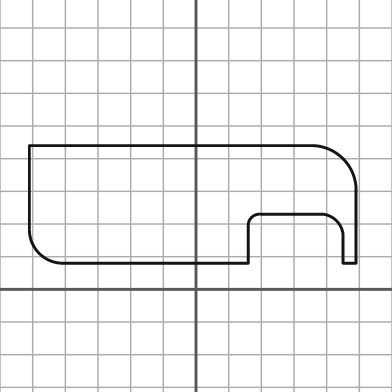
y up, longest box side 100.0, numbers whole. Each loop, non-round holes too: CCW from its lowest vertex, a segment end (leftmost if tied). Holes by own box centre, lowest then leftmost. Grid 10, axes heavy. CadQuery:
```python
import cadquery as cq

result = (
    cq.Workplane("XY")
    .moveTo(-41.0, 8.0)
    .lineTo(16.0, 8.0)
    .lineTo(16.0, 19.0)
    .threePointArc((17.0, 22.0), (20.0, 23.0))
    .lineTo(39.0, 23.0)
    .threePointArc((43.0, 21.0), (45.0, 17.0))
    .lineTo(45.0, 8.0)
    .lineTo(49.0, 8.0)
    .lineTo(49.0, 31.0)
    .threePointArc((45.0, 40.0), (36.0, 44.0))
    .lineTo(-51.0, 44.0)
    .lineTo(-51.0, 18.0)
    .threePointArc((-48.0, 11.0), (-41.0, 8.0))
    .close()
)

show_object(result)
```